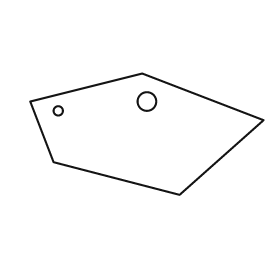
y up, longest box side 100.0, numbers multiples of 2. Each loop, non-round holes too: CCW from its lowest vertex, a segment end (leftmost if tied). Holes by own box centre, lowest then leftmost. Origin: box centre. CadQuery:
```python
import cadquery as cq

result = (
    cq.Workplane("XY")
    .moveTo(14.0, -26.0)
    .lineTo(50.0, 6.0)
    .lineTo(-2.0, 26.0)
    .lineTo(-50.0, 14.0)
    .lineTo(-40.0, -12.0)
    .close()
    .moveTo(-38.0, 10.0)
    .circle(2.0)
    .moveTo(0.0, 14.0)
    .circle(4.0)
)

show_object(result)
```